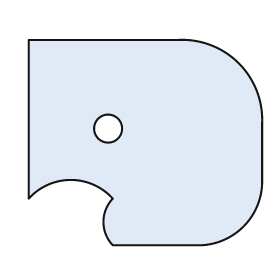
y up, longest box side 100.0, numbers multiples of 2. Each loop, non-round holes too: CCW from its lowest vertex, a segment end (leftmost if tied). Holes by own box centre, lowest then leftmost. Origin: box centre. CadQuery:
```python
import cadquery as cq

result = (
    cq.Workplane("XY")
    .moveTo(-14.0, -44.0)
    .lineTo(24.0, -44.0)
    .threePointArc((42.0, -36.0), (50.0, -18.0))
    .lineTo(50.0, 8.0)
    .threePointArc((40.0, 34.0), (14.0, 44.0))
    .lineTo(-50.0, 44.0)
    .lineTo(-50.0, -24.0)
    .threePointArc((-32.0, -16.0), (-14.0, -24.0))
    .threePointArc((-18.0, -34.0), (-14.0, -44.0))
    .close()
    .moveTo(-16.0, 6.0)
    .circle(6.0)
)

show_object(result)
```